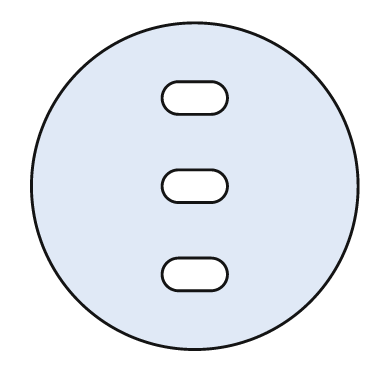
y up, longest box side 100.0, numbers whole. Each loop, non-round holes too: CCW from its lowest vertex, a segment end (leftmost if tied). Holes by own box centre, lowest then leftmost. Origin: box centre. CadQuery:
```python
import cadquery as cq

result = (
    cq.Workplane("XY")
    .moveTo(0.0, 0.0)
    .circle(50.0)
    .moveTo(-5.0, -32.0)
    .lineTo(5.0, -32.0)
    .threePointArc((10.0, -27.0), (5.0, -22.0))
    .lineTo(-5.0, -22.0)
    .threePointArc((-10.0, -27.0), (-5.0, -32.0))
    .close()
    .moveTo(-5.0, -5.0)
    .lineTo(5.0, -5.0)
    .threePointArc((10.0, 0.0), (5.0, 5.0))
    .lineTo(-5.0, 5.0)
    .threePointArc((-10.0, 0.0), (-5.0, -5.0))
    .close()
    .moveTo(-5.0, 22.0)
    .lineTo(5.0, 22.0)
    .threePointArc((10.0, 27.0), (5.0, 32.0))
    .lineTo(-5.0, 32.0)
    .threePointArc((-10.0, 27.0), (-5.0, 22.0))
    .close()
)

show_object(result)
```